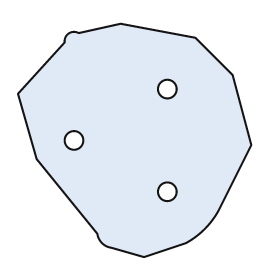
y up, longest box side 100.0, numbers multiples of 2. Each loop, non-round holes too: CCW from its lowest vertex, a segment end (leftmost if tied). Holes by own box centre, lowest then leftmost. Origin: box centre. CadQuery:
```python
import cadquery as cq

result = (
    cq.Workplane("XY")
    .moveTo(4.0, -50.0)
    .lineTo(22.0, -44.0)
    .threePointArc((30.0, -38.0), (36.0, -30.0))
    .lineTo(50.0, -2.0)
    .lineTo(42.0, 28.0)
    .lineTo(26.0, 44.0)
    .lineTo(-6.0, 50.0)
    .lineTo(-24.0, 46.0)
    .threePointArc((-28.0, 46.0), (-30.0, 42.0))
    .lineTo(-50.0, 20.0)
    .lineTo(-42.0, -8.0)
    .lineTo(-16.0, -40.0)
    .threePointArc((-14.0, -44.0), (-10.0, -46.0))
    .close()
    .moveTo(14.0, -22.0)
    .circle(4.0)
    .moveTo(-26.0, 0.0)
    .circle(4.0)
    .moveTo(14.0, 22.0)
    .circle(4.0)
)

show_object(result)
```